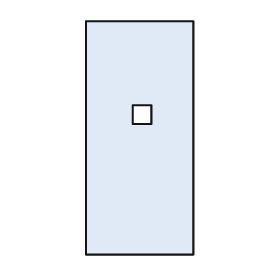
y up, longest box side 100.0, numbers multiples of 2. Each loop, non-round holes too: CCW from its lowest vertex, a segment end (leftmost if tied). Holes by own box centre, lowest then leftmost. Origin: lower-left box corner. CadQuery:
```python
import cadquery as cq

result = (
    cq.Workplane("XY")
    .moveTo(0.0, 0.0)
    .lineTo(46.0, 0.0)
    .lineTo(46.0, 100.0)
    .lineTo(0.0, 100.0)
    .close()
    .moveTo(20.0, 56.0)
    .lineTo(28.0, 56.0)
    .lineTo(28.0, 64.0)
    .lineTo(20.0, 64.0)
    .close()
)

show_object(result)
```